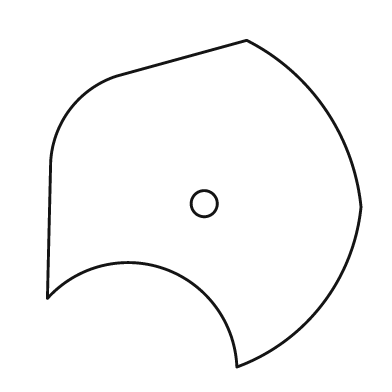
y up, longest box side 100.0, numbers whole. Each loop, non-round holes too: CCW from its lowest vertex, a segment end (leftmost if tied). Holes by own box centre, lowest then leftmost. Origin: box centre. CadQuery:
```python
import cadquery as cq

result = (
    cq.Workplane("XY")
    .moveTo(10.0, -50.0)
    .threePointArc((36.0, -31.0), (48.0, -1.0))
    .threePointArc((37.0, 29.0), (13.0, 50.0))
    .lineTo(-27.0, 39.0)
    .threePointArc((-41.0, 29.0), (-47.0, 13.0))
    .lineTo(-48.0, -29.0)
    .threePointArc((-12.0, -20.0), (10.0, -50.0))
    .close()
    .moveTo(0.0, 0.0)
    .circle(4.0)
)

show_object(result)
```